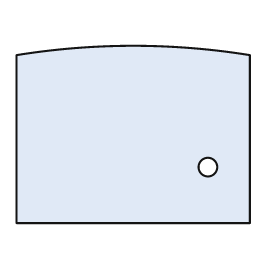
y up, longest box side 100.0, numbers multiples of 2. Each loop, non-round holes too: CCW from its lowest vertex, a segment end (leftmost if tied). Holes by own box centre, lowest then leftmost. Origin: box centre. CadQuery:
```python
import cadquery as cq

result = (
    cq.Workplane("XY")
    .moveTo(-50.0, -38.0)
    .lineTo(50.0, -38.0)
    .lineTo(50.0, 34.0)
    .threePointArc((0.0, 38.0), (-50.0, 34.0))
    .close()
    .moveTo(32.0, -14.0)
    .circle(4.0)
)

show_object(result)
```